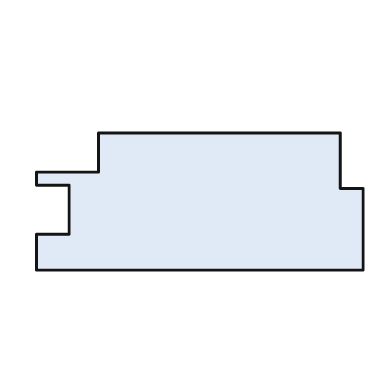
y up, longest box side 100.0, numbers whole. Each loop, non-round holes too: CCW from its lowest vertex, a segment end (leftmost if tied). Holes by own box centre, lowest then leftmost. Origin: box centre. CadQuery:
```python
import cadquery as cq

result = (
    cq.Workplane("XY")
    .moveTo(-50.0, -21.0)
    .lineTo(50.0, -21.0)
    .lineTo(50.0, 4.0)
    .lineTo(43.0, 4.0)
    .lineTo(43.0, 21.0)
    .lineTo(-31.0, 21.0)
    .lineTo(-31.0, 9.0)
    .lineTo(-50.0, 9.0)
    .lineTo(-50.0, 5.0)
    .lineTo(-40.0, 5.0)
    .lineTo(-40.0, -10.0)
    .lineTo(-50.0, -10.0)
    .close()
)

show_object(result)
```